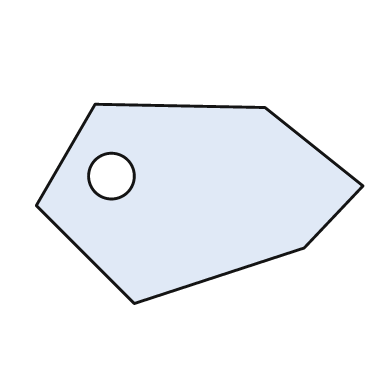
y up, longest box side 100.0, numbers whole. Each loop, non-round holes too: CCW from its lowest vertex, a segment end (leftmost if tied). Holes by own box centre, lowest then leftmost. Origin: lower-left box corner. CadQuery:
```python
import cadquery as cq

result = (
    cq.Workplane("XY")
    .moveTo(30.0, 0.0)
    .lineTo(82.0, 17.0)
    .lineTo(100.0, 36.0)
    .lineTo(70.0, 60.0)
    .lineTo(18.0, 61.0)
    .lineTo(0.0, 30.0)
    .close()
    .moveTo(23.0, 39.0)
    .circle(7.0)
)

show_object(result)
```